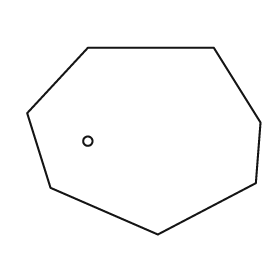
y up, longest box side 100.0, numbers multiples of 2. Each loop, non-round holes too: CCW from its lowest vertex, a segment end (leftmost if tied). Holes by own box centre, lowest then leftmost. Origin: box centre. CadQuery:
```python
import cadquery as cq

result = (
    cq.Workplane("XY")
    .moveTo(6.0, -40.0)
    .lineTo(48.0, -18.0)
    .lineTo(50.0, 8.0)
    .lineTo(30.0, 40.0)
    .lineTo(-24.0, 40.0)
    .lineTo(-50.0, 12.0)
    .lineTo(-40.0, -20.0)
    .close()
    .moveTo(-24.0, 0.0)
    .circle(2.0)
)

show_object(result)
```